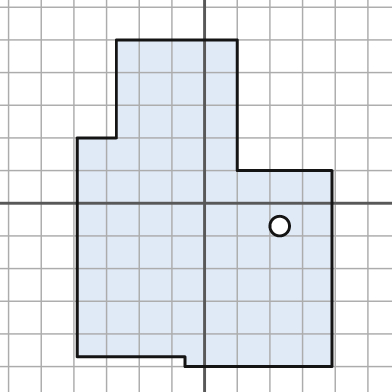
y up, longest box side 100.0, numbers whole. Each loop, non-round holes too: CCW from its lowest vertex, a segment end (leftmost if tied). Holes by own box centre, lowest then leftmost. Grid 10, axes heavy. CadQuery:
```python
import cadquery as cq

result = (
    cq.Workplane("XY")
    .moveTo(-6.0, -50.0)
    .lineTo(39.0, -50.0)
    .lineTo(39.0, 10.0)
    .lineTo(10.0, 10.0)
    .lineTo(10.0, 50.0)
    .lineTo(-27.0, 50.0)
    .lineTo(-27.0, 20.0)
    .lineTo(-39.0, 20.0)
    .lineTo(-39.0, -47.0)
    .lineTo(-6.0, -47.0)
    .close()
    .moveTo(23.0, -7.0)
    .circle(3.0)
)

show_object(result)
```